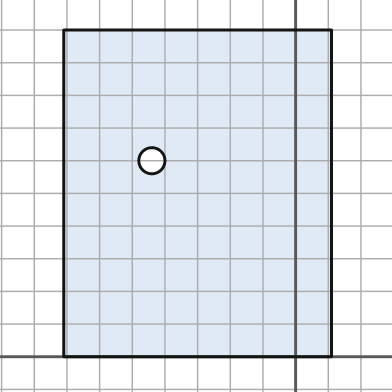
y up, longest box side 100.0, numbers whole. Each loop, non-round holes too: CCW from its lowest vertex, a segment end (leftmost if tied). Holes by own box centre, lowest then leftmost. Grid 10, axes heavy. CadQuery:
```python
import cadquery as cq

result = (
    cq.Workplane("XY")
    .moveTo(-71.0, 0.0)
    .lineTo(11.0, 0.0)
    .lineTo(11.0, 100.0)
    .lineTo(-71.0, 100.0)
    .close()
    .moveTo(-44.0, 60.0)
    .circle(4.0)
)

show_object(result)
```